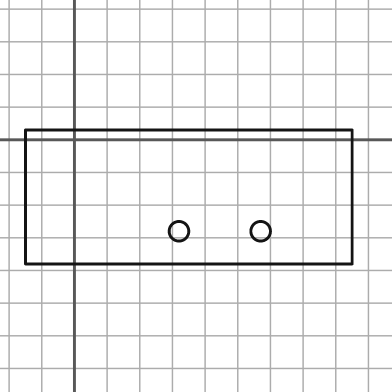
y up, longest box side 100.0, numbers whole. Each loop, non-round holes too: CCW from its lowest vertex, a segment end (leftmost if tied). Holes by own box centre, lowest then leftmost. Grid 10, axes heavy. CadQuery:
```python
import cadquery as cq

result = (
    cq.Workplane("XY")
    .moveTo(-15.0, -38.0)
    .lineTo(85.0, -38.0)
    .lineTo(85.0, 3.0)
    .lineTo(-15.0, 3.0)
    .close()
    .moveTo(32.0, -28.0)
    .circle(3.0)
    .moveTo(57.0, -28.0)
    .circle(3.0)
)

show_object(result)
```